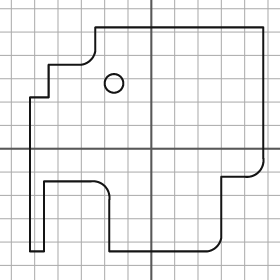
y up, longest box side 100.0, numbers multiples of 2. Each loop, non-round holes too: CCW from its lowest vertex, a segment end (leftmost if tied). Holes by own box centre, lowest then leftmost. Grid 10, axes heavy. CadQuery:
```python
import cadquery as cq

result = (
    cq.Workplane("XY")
    .moveTo(-52.0, -44.0)
    .lineTo(-46.0, -44.0)
    .lineTo(-46.0, -14.0)
    .lineTo(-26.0, -14.0)
    .threePointArc((-20.0, -16.0), (-18.0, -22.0))
    .lineTo(-18.0, -44.0)
    .lineTo(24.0, -44.0)
    .threePointArc((28.0, -42.0), (30.0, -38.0))
    .lineTo(30.0, -12.0)
    .lineTo(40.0, -12.0)
    .threePointArc((46.0, -10.0), (48.0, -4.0))
    .lineTo(48.0, 52.0)
    .lineTo(-24.0, 52.0)
    .lineTo(-24.0, 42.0)
    .threePointArc((-26.0, 38.0), (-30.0, 36.0))
    .lineTo(-44.0, 36.0)
    .lineTo(-44.0, 22.0)
    .lineTo(-52.0, 22.0)
    .close()
    .moveTo(-16.0, 28.0)
    .circle(4.0)
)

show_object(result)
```